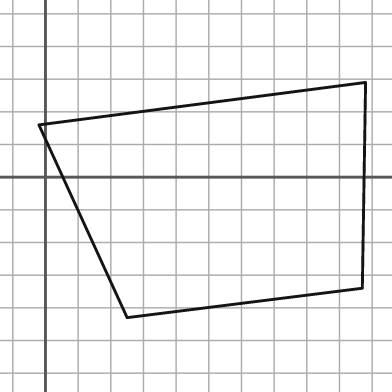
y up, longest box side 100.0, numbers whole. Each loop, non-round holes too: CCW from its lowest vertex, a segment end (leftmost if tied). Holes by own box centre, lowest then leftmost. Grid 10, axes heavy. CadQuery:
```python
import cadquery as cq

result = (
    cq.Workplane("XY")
    .moveTo(25.0, -43.0)
    .lineTo(97.0, -34.0)
    .lineTo(98.0, 29.0)
    .lineTo(-2.0, 16.0)
    .close()
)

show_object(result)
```